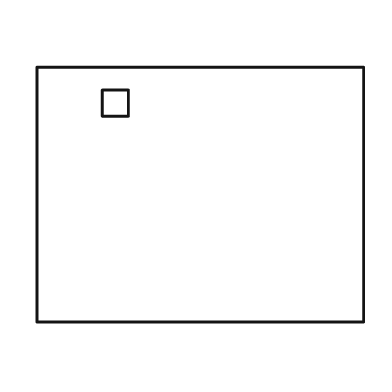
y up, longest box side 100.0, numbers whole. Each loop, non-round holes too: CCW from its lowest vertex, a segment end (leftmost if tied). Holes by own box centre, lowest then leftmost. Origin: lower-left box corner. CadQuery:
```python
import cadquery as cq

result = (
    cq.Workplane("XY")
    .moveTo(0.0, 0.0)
    .lineTo(100.0, 0.0)
    .lineTo(100.0, 78.0)
    .lineTo(0.0, 78.0)
    .close()
    .moveTo(20.0, 63.0)
    .lineTo(28.0, 63.0)
    .lineTo(28.0, 71.0)
    .lineTo(20.0, 71.0)
    .close()
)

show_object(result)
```